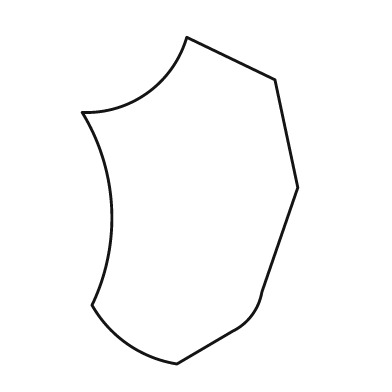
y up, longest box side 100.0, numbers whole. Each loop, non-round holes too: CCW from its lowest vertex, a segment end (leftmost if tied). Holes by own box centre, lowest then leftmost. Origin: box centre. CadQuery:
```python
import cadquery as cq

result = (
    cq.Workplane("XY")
    .moveTo(-4.0, -50.0)
    .lineTo(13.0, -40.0)
    .threePointArc((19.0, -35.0), (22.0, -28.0))
    .lineTo(33.0, 4.0)
    .lineTo(26.0, 37.0)
    .lineTo(-1.0, 50.0)
    .threePointArc((-13.0, 33.0), (-33.0, 27.0))
    .threePointArc((-24.0, -2.0), (-30.0, -32.0))
    .threePointArc((-19.0, -44.0), (-4.0, -50.0))
    .close()
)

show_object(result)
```